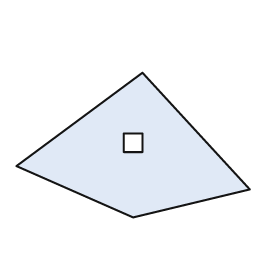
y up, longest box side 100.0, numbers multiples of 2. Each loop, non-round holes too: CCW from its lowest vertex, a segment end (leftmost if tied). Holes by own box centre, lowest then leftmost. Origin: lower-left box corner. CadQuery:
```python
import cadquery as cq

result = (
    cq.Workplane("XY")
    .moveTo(50.0, 0.0)
    .lineTo(100.0, 12.0)
    .lineTo(54.0, 62.0)
    .lineTo(0.0, 22.0)
    .close()
    .moveTo(46.0, 28.0)
    .lineTo(54.0, 28.0)
    .lineTo(54.0, 36.0)
    .lineTo(46.0, 36.0)
    .close()
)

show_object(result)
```